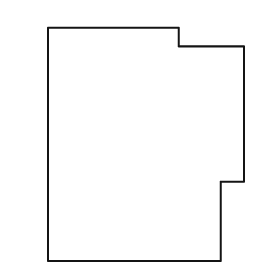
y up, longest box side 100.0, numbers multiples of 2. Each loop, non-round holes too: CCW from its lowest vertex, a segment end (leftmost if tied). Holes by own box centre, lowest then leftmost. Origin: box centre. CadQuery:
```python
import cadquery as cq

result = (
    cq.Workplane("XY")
    .moveTo(-42.0, -50.0)
    .lineTo(32.0, -50.0)
    .lineTo(32.0, -16.0)
    .lineTo(42.0, -16.0)
    .lineTo(42.0, 42.0)
    .lineTo(14.0, 42.0)
    .lineTo(14.0, 50.0)
    .lineTo(-42.0, 50.0)
    .close()
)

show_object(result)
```